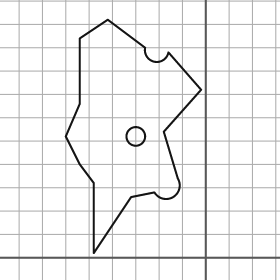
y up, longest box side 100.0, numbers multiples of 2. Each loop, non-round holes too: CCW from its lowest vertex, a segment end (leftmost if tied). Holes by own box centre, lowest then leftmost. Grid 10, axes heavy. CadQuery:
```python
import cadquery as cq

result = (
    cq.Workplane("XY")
    .moveTo(-48.0, 2.0)
    .lineTo(-32.0, 26.0)
    .lineTo(-22.0, 28.0)
    .threePointArc((-14.0, 26.0), (-12.0, 34.0))
    .lineTo(-18.0, 54.0)
    .lineTo(-2.0, 72.0)
    .lineTo(-16.0, 88.0)
    .threePointArc((-22.0, 84.0), (-26.0, 90.0))
    .lineTo(-42.0, 102.0)
    .lineTo(-54.0, 94.0)
    .lineTo(-54.0, 66.0)
    .lineTo(-60.0, 52.0)
    .lineTo(-54.0, 40.0)
    .lineTo(-48.0, 32.0)
    .close()
    .moveTo(-30.0, 52.0)
    .circle(4.0)
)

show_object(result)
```